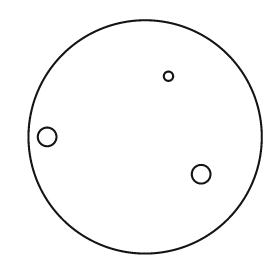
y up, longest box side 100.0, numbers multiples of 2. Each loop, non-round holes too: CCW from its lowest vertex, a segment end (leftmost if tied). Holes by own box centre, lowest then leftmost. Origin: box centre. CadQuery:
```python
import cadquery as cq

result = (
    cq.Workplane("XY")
    .moveTo(0.0, 0.0)
    .circle(50.0)
    .moveTo(24.0, -16.0)
    .circle(4.0)
    .moveTo(-42.0, 0.0)
    .circle(4.0)
    .moveTo(10.0, 26.0)
    .circle(2.0)
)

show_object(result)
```